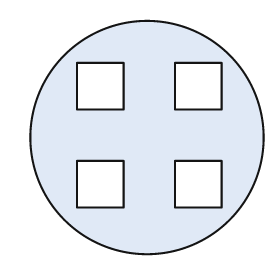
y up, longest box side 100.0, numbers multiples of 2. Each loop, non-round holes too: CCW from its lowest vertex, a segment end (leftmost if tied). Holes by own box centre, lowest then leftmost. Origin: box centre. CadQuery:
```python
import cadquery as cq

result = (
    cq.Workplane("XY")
    .moveTo(0.0, 0.0)
    .circle(50.0)
    .moveTo(-30.0, -30.0)
    .lineTo(-10.0, -30.0)
    .lineTo(-10.0, -10.0)
    .lineTo(-30.0, -10.0)
    .close()
    .moveTo(12.0, -30.0)
    .lineTo(32.0, -30.0)
    .lineTo(32.0, -10.0)
    .lineTo(12.0, -10.0)
    .close()
    .moveTo(-30.0, 12.0)
    .lineTo(-10.0, 12.0)
    .lineTo(-10.0, 32.0)
    .lineTo(-30.0, 32.0)
    .close()
    .moveTo(12.0, 12.0)
    .lineTo(32.0, 12.0)
    .lineTo(32.0, 32.0)
    .lineTo(12.0, 32.0)
    .close()
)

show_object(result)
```